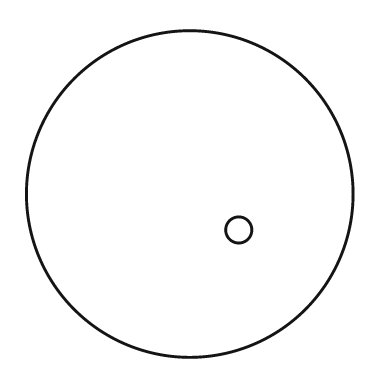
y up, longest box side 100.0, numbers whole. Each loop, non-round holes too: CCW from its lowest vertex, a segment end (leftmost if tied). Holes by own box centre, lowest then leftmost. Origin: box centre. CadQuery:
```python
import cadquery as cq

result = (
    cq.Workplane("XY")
    .moveTo(0.0, 0.0)
    .circle(50.0)
    .moveTo(15.0, -11.0)
    .circle(4.0)
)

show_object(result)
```